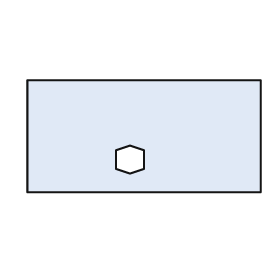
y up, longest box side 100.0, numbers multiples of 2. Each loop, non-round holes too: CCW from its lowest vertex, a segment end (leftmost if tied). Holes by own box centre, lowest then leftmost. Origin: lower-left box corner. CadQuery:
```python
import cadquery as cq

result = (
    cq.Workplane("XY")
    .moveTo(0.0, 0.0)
    .lineTo(100.0, 0.0)
    .lineTo(100.0, 48.0)
    .lineTo(0.0, 48.0)
    .close()
    .moveTo(44.0, 8.0)
    .lineTo(50.0, 10.0)
    .lineTo(50.0, 18.0)
    .lineTo(44.0, 20.0)
    .lineTo(38.0, 18.0)
    .lineTo(38.0, 10.0)
    .close()
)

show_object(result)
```